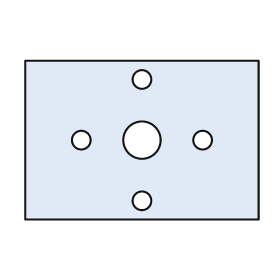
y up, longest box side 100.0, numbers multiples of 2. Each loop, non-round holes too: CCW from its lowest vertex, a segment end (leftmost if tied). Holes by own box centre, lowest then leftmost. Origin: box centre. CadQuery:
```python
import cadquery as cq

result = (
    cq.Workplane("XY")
    .moveTo(-50.0, -34.0)
    .lineTo(50.0, -34.0)
    .lineTo(50.0, 34.0)
    .lineTo(-50.0, 34.0)
    .close()
    .moveTo(0.0, -26.0)
    .circle(4.0)
    .moveTo(-26.0, 0.0)
    .circle(4.0)
    .moveTo(0.0, 0.0)
    .circle(8.0)
    .moveTo(26.0, 0.0)
    .circle(4.0)
    .moveTo(0.0, 26.0)
    .circle(4.0)
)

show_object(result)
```